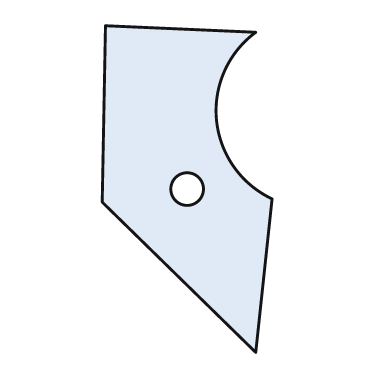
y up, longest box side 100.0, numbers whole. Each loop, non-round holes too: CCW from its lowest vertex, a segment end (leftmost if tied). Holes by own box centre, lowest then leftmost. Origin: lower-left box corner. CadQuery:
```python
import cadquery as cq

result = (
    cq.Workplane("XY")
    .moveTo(47.0, 0.0)
    .lineTo(52.0, 47.0)
    .threePointArc((35.0, 71.0), (47.0, 98.0))
    .lineTo(1.0, 100.0)
    .lineTo(0.0, 46.0)
    .close()
    .moveTo(26.0, 50.0)
    .circle(5.0)
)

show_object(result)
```